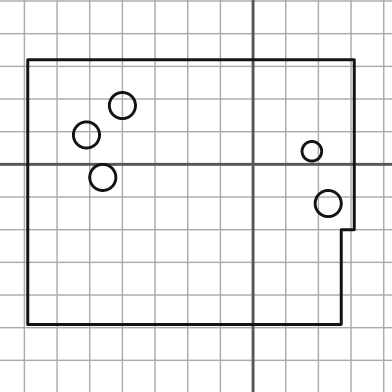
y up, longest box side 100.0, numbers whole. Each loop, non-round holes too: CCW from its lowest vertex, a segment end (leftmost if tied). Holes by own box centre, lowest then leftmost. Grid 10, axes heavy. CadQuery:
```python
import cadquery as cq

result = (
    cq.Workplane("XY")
    .moveTo(-69.0, -49.0)
    .lineTo(27.0, -49.0)
    .lineTo(27.0, -20.0)
    .lineTo(31.0, -20.0)
    .lineTo(31.0, 32.0)
    .lineTo(-69.0, 32.0)
    .close()
    .moveTo(23.0, -12.0)
    .circle(4.0)
    .moveTo(-46.0, -4.0)
    .circle(4.0)
    .moveTo(18.0, 4.0)
    .circle(3.0)
    .moveTo(-51.0, 9.0)
    .circle(4.0)
    .moveTo(-40.0, 18.0)
    .circle(4.0)
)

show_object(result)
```